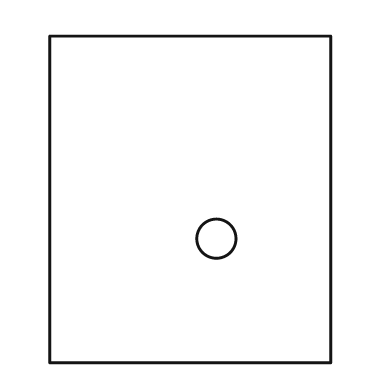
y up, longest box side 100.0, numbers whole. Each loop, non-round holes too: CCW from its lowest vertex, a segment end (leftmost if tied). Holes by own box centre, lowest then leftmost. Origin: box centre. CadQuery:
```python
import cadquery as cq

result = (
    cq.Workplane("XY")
    .moveTo(-43.0, -50.0)
    .lineTo(43.0, -50.0)
    .lineTo(43.0, 50.0)
    .lineTo(-43.0, 50.0)
    .close()
    .moveTo(8.0, -12.0)
    .circle(6.0)
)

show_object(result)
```